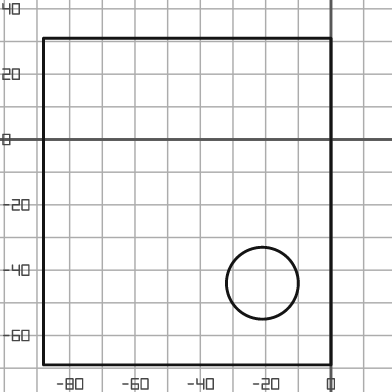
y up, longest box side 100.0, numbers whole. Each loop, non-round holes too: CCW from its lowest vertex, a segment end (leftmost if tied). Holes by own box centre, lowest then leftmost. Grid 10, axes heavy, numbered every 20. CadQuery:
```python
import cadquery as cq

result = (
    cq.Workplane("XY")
    .moveTo(-88.0, -69.0)
    .lineTo(0.0, -69.0)
    .lineTo(0.0, 31.0)
    .lineTo(-88.0, 31.0)
    .close()
    .moveTo(-21.0, -44.0)
    .circle(11.0)
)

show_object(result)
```